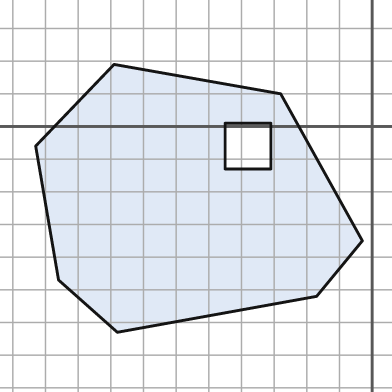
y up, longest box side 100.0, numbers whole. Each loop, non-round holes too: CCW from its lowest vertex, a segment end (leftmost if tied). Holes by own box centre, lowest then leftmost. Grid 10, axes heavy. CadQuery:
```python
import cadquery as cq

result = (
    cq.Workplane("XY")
    .moveTo(-78.0, -63.0)
    .lineTo(-17.0, -52.0)
    .lineTo(-3.0, -35.0)
    .lineTo(-28.0, 10.0)
    .lineTo(-79.0, 19.0)
    .lineTo(-103.0, -6.0)
    .lineTo(-96.0, -47.0)
    .close()
    .moveTo(-45.0, -13.0)
    .lineTo(-31.0, -13.0)
    .lineTo(-31.0, 1.0)
    .lineTo(-45.0, 1.0)
    .close()
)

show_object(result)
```